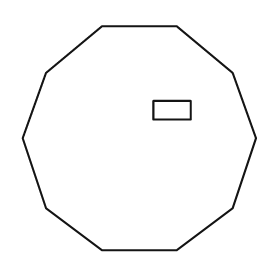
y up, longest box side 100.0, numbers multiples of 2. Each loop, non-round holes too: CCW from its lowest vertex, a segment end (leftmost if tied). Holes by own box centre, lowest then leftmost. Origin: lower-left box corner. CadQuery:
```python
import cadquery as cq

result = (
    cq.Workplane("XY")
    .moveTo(34.0, 0.0)
    .lineTo(66.0, 0.0)
    .lineTo(90.0, 18.0)
    .lineTo(100.0, 48.0)
    .lineTo(90.0, 76.0)
    .lineTo(66.0, 96.0)
    .lineTo(34.0, 96.0)
    .lineTo(10.0, 76.0)
    .lineTo(0.0, 48.0)
    .lineTo(10.0, 18.0)
    .close()
    .moveTo(56.0, 56.0)
    .lineTo(72.0, 56.0)
    .lineTo(72.0, 64.0)
    .lineTo(56.0, 64.0)
    .close()
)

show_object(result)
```